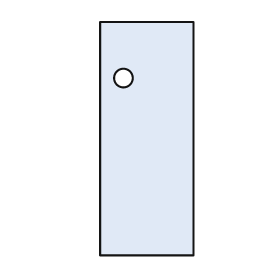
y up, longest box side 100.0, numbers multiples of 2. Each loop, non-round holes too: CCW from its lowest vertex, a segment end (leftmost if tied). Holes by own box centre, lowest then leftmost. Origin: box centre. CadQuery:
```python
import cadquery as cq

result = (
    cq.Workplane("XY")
    .moveTo(-20.0, -50.0)
    .lineTo(20.0, -50.0)
    .lineTo(20.0, 50.0)
    .lineTo(-20.0, 50.0)
    .close()
    .moveTo(-10.0, 26.0)
    .circle(4.0)
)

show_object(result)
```